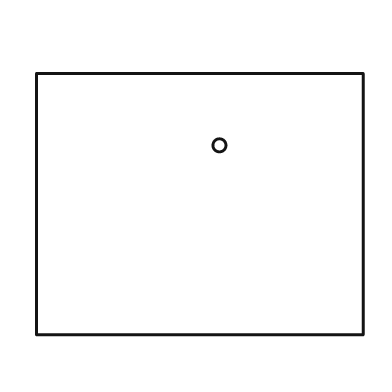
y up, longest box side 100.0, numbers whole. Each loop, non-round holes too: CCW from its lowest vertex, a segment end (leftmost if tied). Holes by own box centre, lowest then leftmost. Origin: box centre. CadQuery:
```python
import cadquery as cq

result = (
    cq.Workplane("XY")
    .moveTo(-50.0, -40.0)
    .lineTo(50.0, -40.0)
    .lineTo(50.0, 40.0)
    .lineTo(-50.0, 40.0)
    .close()
    .moveTo(6.0, 18.0)
    .circle(2.0)
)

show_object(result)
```